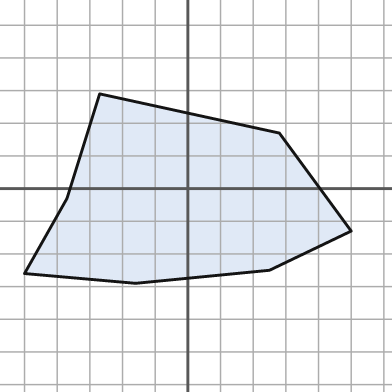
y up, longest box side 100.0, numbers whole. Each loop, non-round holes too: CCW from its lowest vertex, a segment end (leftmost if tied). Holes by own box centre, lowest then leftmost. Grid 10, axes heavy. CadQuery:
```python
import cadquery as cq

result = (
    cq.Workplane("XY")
    .moveTo(-16.0, -29.0)
    .lineTo(25.0, -25.0)
    .lineTo(50.0, -13.0)
    .lineTo(28.0, 17.0)
    .lineTo(-27.0, 29.0)
    .lineTo(-37.0, -3.0)
    .lineTo(-50.0, -26.0)
    .close()
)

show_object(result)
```